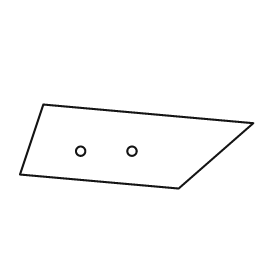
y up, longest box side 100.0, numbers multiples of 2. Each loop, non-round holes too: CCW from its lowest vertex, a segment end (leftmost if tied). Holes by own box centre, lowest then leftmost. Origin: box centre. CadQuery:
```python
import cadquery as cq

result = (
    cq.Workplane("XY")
    .moveTo(18.0, -18.0)
    .lineTo(50.0, 10.0)
    .lineTo(-40.0, 18.0)
    .lineTo(-50.0, -12.0)
    .close()
    .moveTo(-24.0, -2.0)
    .circle(2.0)
    .moveTo(-2.0, -2.0)
    .circle(2.0)
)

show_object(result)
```